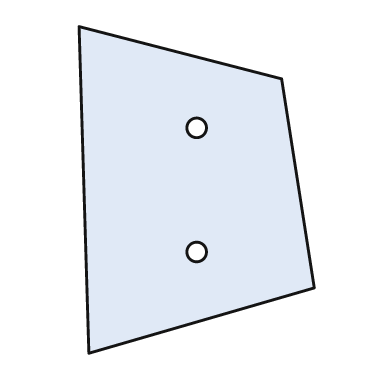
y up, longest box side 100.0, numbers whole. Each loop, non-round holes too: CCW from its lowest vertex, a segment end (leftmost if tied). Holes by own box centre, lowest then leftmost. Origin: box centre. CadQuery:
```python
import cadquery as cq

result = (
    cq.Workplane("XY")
    .moveTo(-33.0, -50.0)
    .lineTo(36.0, -30.0)
    .lineTo(26.0, 34.0)
    .lineTo(-36.0, 50.0)
    .close()
    .moveTo(0.0, -19.0)
    .circle(3.0)
    .moveTo(0.0, 19.0)
    .circle(3.0)
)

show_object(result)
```